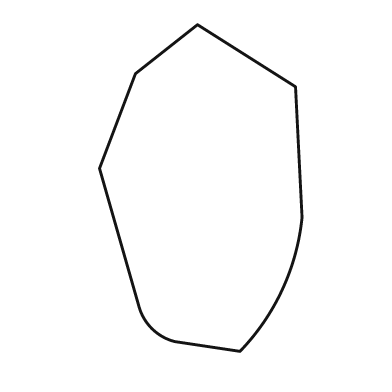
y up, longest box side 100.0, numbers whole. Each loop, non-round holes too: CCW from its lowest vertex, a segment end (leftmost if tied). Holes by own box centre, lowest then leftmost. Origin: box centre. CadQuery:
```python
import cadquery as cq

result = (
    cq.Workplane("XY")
    .moveTo(12.0, -50.0)
    .threePointArc((25.0, -31.0), (31.0, -9.0))
    .lineTo(29.0, 31.0)
    .lineTo(-1.0, 50.0)
    .lineTo(-20.0, 35.0)
    .lineTo(-31.0, 6.0)
    .lineTo(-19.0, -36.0)
    .threePointArc((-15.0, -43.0), (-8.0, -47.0))
    .close()
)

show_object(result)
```